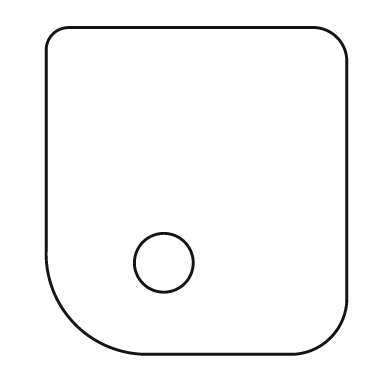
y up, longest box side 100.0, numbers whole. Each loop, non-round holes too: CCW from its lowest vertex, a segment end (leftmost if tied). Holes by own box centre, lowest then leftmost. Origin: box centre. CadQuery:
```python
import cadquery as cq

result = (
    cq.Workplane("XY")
    .moveTo(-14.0, -50.0)
    .lineTo(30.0, -50.0)
    .threePointArc((41.0, -45.0), (46.0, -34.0))
    .lineTo(46.0, 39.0)
    .threePointArc((43.0, 47.0), (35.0, 50.0))
    .lineTo(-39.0, 50.0)
    .threePointArc((-44.0, 48.0), (-46.0, 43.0))
    .lineTo(-46.0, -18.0)
    .threePointArc((-37.0, -41.0), (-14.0, -50.0))
    .close()
    .moveTo(-10.0, -22.0)
    .circle(9.0)
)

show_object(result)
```